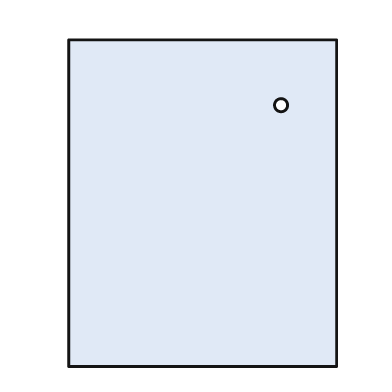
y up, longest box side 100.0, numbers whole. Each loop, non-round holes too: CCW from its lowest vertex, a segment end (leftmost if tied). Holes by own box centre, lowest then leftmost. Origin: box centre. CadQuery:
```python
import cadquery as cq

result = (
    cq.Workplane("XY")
    .moveTo(-41.0, -50.0)
    .lineTo(41.0, -50.0)
    .lineTo(41.0, 50.0)
    .lineTo(-41.0, 50.0)
    .close()
    .moveTo(24.0, 30.0)
    .circle(2.0)
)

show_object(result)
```